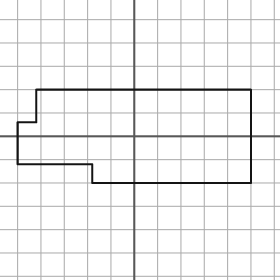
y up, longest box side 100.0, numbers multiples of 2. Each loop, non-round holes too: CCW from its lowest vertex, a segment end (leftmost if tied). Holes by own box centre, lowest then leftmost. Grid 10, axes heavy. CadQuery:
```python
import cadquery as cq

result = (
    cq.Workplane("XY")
    .moveTo(-18.0, -20.0)
    .lineTo(50.0, -20.0)
    .lineTo(50.0, 20.0)
    .lineTo(-42.0, 20.0)
    .lineTo(-42.0, 6.0)
    .lineTo(-50.0, 6.0)
    .lineTo(-50.0, -12.0)
    .lineTo(-18.0, -12.0)
    .close()
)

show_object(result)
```